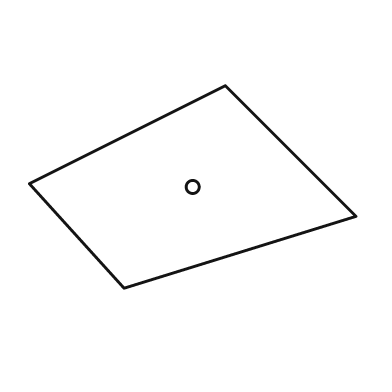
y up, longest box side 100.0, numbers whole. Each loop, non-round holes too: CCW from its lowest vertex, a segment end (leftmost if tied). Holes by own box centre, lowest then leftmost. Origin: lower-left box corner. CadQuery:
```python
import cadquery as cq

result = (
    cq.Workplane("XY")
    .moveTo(29.0, 0.0)
    .lineTo(100.0, 22.0)
    .lineTo(60.0, 62.0)
    .lineTo(0.0, 32.0)
    .close()
    .moveTo(50.0, 31.0)
    .circle(2.0)
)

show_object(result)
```